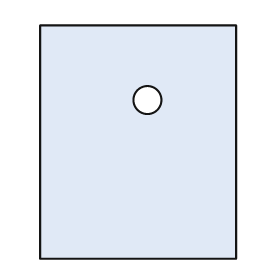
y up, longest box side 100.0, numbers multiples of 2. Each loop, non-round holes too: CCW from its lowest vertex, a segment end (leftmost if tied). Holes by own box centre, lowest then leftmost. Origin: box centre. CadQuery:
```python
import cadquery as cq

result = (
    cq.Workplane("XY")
    .moveTo(-42.0, -50.0)
    .lineTo(42.0, -50.0)
    .lineTo(42.0, 50.0)
    .lineTo(-42.0, 50.0)
    .close()
    .moveTo(4.0, 18.0)
    .circle(6.0)
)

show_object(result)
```